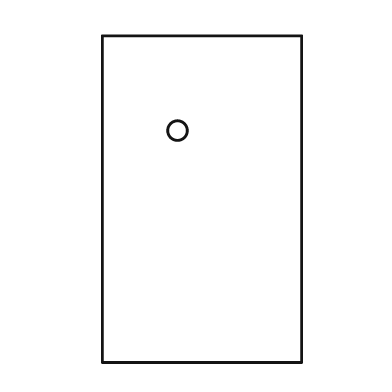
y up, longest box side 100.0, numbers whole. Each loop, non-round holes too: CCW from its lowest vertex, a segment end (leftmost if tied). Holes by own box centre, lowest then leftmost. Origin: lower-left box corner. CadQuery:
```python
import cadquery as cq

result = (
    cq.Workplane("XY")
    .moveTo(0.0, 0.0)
    .lineTo(61.0, 0.0)
    .lineTo(61.0, 100.0)
    .lineTo(0.0, 100.0)
    .close()
    .moveTo(23.0, 71.0)
    .circle(3.0)
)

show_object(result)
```